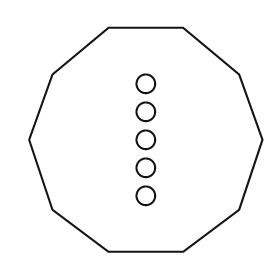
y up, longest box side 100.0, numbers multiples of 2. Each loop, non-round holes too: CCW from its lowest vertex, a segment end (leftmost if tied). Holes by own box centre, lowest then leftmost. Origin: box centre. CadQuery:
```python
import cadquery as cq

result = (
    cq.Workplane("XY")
    .moveTo(-16.0, -48.0)
    .lineTo(16.0, -48.0)
    .lineTo(40.0, -30.0)
    .lineTo(50.0, 0.0)
    .lineTo(40.0, 28.0)
    .lineTo(16.0, 48.0)
    .lineTo(-16.0, 48.0)
    .lineTo(-40.0, 28.0)
    .lineTo(-50.0, 0.0)
    .lineTo(-40.0, -30.0)
    .close()
    .moveTo(0.0, -24.0)
    .circle(4.0)
    .moveTo(0.0, -12.0)
    .circle(4.0)
    .moveTo(0.0, 0.0)
    .circle(4.0)
    .moveTo(0.0, 12.0)
    .circle(4.0)
    .moveTo(0.0, 24.0)
    .circle(4.0)
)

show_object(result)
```